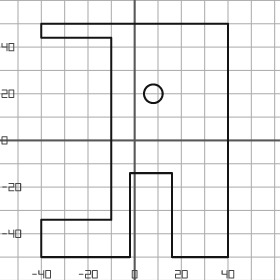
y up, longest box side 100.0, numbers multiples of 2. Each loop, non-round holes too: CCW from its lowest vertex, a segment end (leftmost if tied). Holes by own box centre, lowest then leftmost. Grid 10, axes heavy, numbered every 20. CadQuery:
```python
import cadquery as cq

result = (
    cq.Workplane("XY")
    .moveTo(-40.0, -50.0)
    .lineTo(-2.0, -50.0)
    .lineTo(-2.0, -14.0)
    .lineTo(16.0, -14.0)
    .lineTo(16.0, -50.0)
    .lineTo(40.0, -50.0)
    .lineTo(40.0, 50.0)
    .lineTo(-40.0, 50.0)
    .lineTo(-40.0, 44.0)
    .lineTo(-10.0, 44.0)
    .lineTo(-10.0, -34.0)
    .lineTo(-40.0, -34.0)
    .close()
    .moveTo(8.0, 20.0)
    .circle(4.0)
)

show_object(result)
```